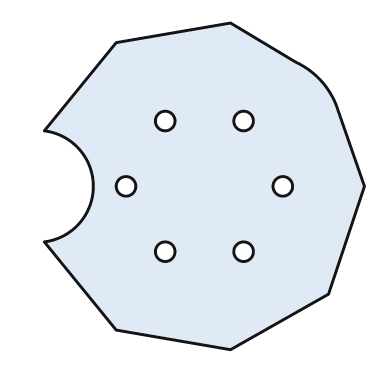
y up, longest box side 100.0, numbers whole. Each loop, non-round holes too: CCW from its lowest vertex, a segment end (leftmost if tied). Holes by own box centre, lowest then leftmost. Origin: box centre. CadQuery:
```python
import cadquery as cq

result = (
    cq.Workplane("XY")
    .moveTo(8.0, -50.0)
    .lineTo(38.0, -33.0)
    .lineTo(49.0, 0.0)
    .lineTo(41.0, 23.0)
    .threePointArc((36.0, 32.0), (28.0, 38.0))
    .lineTo(8.0, 50.0)
    .lineTo(-27.0, 44.0)
    .lineTo(-49.0, 17.0)
    .threePointArc((-34.0, 0.0), (-49.0, -17.0))
    .lineTo(-27.0, -44.0)
    .close()
    .moveTo(-12.0, -20.0)
    .circle(3.0)
    .moveTo(12.0, -20.0)
    .circle(3.0)
    .moveTo(-24.0, 0.0)
    .circle(3.0)
    .moveTo(24.0, 0.0)
    .circle(3.0)
    .moveTo(-12.0, 20.0)
    .circle(3.0)
    .moveTo(12.0, 20.0)
    .circle(3.0)
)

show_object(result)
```